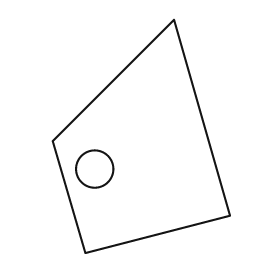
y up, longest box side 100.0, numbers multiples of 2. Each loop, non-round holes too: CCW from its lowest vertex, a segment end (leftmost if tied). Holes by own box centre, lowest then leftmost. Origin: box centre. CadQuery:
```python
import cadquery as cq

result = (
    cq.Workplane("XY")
    .moveTo(-24.0, -50.0)
    .lineTo(38.0, -34.0)
    .lineTo(14.0, 50.0)
    .lineTo(-38.0, -2.0)
    .close()
    .moveTo(-20.0, -14.0)
    .circle(8.0)
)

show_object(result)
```